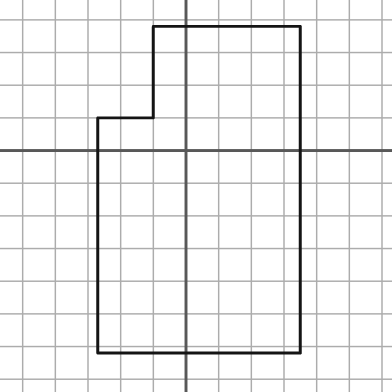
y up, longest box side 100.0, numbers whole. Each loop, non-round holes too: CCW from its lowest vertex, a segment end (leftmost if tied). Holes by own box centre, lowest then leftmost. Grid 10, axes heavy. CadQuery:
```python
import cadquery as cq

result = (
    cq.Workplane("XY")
    .moveTo(-27.0, -62.0)
    .lineTo(35.0, -62.0)
    .lineTo(35.0, 38.0)
    .lineTo(-10.0, 38.0)
    .lineTo(-10.0, 10.0)
    .lineTo(-27.0, 10.0)
    .close()
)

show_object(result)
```